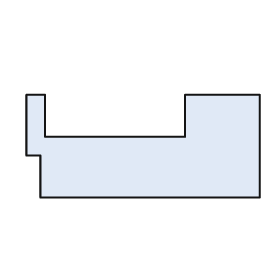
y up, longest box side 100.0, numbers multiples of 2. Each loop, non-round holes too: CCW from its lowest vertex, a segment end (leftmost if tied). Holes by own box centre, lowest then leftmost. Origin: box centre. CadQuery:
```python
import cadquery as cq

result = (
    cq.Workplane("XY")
    .moveTo(-44.0, -22.0)
    .lineTo(50.0, -22.0)
    .lineTo(50.0, 22.0)
    .lineTo(18.0, 22.0)
    .lineTo(18.0, 4.0)
    .lineTo(-42.0, 4.0)
    .lineTo(-42.0, 22.0)
    .lineTo(-50.0, 22.0)
    .lineTo(-50.0, -4.0)
    .lineTo(-44.0, -4.0)
    .close()
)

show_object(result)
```